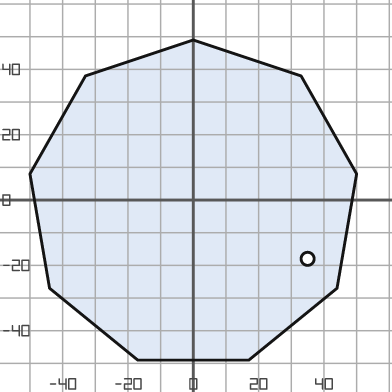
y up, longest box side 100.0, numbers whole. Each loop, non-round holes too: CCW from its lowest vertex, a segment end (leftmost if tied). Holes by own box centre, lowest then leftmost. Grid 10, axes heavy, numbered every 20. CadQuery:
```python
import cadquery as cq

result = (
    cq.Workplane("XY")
    .moveTo(-17.0, -49.0)
    .lineTo(17.0, -49.0)
    .lineTo(44.0, -27.0)
    .lineTo(50.0, 8.0)
    .lineTo(33.0, 38.0)
    .lineTo(0.0, 49.0)
    .lineTo(-33.0, 38.0)
    .lineTo(-50.0, 8.0)
    .lineTo(-44.0, -27.0)
    .close()
    .moveTo(35.0, -18.0)
    .circle(2.0)
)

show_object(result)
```